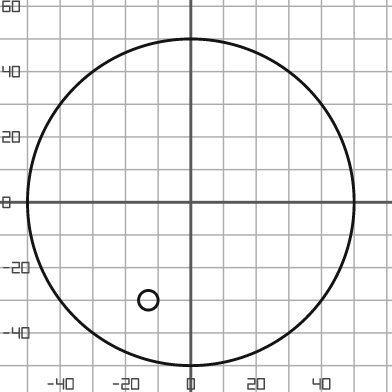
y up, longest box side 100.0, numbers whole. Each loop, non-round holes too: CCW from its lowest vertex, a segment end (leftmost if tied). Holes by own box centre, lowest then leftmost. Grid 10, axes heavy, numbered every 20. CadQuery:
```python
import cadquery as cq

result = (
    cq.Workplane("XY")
    .moveTo(0.0, 0.0)
    .circle(50.0)
    .moveTo(-13.0, -30.0)
    .circle(3.0)
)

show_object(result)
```